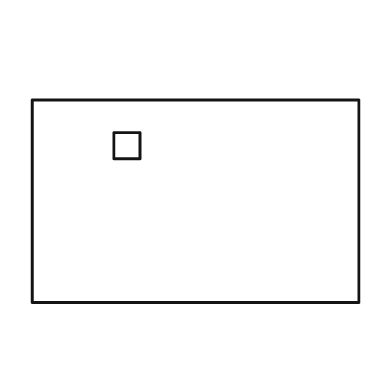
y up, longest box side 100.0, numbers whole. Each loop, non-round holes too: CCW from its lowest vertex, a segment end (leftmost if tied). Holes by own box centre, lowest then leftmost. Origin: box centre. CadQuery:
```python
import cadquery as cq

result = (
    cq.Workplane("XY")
    .moveTo(-50.0, -31.0)
    .lineTo(50.0, -31.0)
    .lineTo(50.0, 31.0)
    .lineTo(-50.0, 31.0)
    .close()
    .moveTo(-25.0, 13.0)
    .lineTo(-17.0, 13.0)
    .lineTo(-17.0, 21.0)
    .lineTo(-25.0, 21.0)
    .close()
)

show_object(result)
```